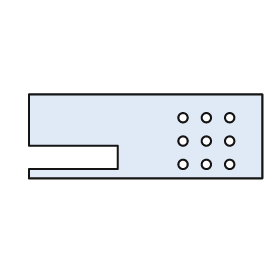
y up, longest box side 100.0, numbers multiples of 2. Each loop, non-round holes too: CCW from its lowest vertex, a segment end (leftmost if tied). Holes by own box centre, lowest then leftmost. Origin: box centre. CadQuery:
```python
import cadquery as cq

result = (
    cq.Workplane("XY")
    .moveTo(-50.0, -18.0)
    .lineTo(50.0, -18.0)
    .lineTo(50.0, 18.0)
    .lineTo(-50.0, 18.0)
    .lineTo(-50.0, -4.0)
    .lineTo(-12.0, -4.0)
    .lineTo(-12.0, -14.0)
    .lineTo(-50.0, -14.0)
    .close()
    .moveTo(16.0, -12.0)
    .circle(2.0)
    .moveTo(26.0, -12.0)
    .circle(2.0)
    .moveTo(36.0, -12.0)
    .circle(2.0)
    .moveTo(16.0, -2.0)
    .circle(2.0)
    .moveTo(26.0, -2.0)
    .circle(2.0)
    .moveTo(36.0, -2.0)
    .circle(2.0)
    .moveTo(16.0, 8.0)
    .circle(2.0)
    .moveTo(26.0, 8.0)
    .circle(2.0)
    .moveTo(36.0, 8.0)
    .circle(2.0)
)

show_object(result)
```